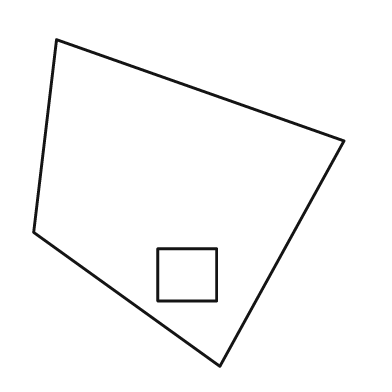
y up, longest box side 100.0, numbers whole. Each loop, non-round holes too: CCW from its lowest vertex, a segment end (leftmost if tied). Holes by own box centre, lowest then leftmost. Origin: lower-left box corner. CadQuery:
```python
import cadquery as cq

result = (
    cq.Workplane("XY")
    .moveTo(57.0, 0.0)
    .lineTo(95.0, 69.0)
    .lineTo(7.0, 100.0)
    .lineTo(0.0, 41.0)
    .close()
    .moveTo(38.0, 20.0)
    .lineTo(56.0, 20.0)
    .lineTo(56.0, 36.0)
    .lineTo(38.0, 36.0)
    .close()
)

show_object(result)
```